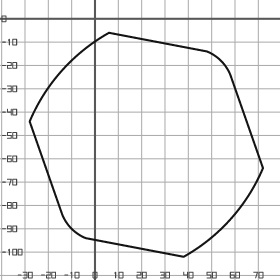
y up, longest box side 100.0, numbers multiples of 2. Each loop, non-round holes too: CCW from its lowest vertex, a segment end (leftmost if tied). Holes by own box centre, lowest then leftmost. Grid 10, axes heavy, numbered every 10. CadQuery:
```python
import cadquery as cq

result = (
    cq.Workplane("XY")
    .moveTo(38.0, -102.0)
    .threePointArc((58.0, -86.0), (72.0, -64.0))
    .lineTo(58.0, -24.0)
    .threePointArc((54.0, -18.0), (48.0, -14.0))
    .lineTo(6.0, -6.0)
    .threePointArc((-14.0, -22.0), (-28.0, -44.0))
    .lineTo(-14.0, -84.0)
    .threePointArc((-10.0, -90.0), (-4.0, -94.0))
    .close()
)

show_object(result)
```